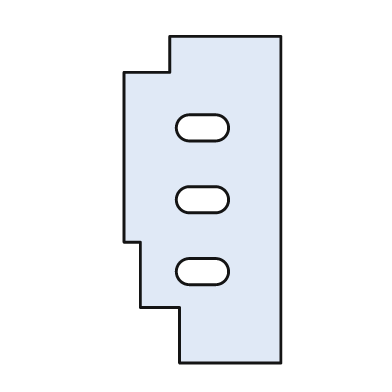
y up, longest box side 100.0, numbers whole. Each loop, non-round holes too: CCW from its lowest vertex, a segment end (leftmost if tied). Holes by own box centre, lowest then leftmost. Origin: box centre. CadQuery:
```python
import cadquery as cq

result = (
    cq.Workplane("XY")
    .moveTo(-7.0, -50.0)
    .lineTo(24.0, -50.0)
    .lineTo(24.0, 50.0)
    .lineTo(-10.0, 50.0)
    .lineTo(-10.0, 39.0)
    .lineTo(-24.0, 39.0)
    .lineTo(-24.0, -13.0)
    .lineTo(-19.0, -13.0)
    .lineTo(-19.0, -33.0)
    .lineTo(-7.0, -33.0)
    .close()
    .moveTo(-4.0, -26.0)
    .lineTo(4.0, -26.0)
    .threePointArc((8.0, -22.0), (4.0, -18.0))
    .lineTo(-4.0, -18.0)
    .threePointArc((-8.0, -22.0), (-4.0, -26.0))
    .close()
    .moveTo(-4.0, -4.0)
    .lineTo(4.0, -4.0)
    .threePointArc((8.0, 0.0), (4.0, 4.0))
    .lineTo(-4.0, 4.0)
    .threePointArc((-8.0, 0.0), (-4.0, -4.0))
    .close()
    .moveTo(-4.0, 18.0)
    .lineTo(4.0, 18.0)
    .threePointArc((8.0, 22.0), (4.0, 26.0))
    .lineTo(-4.0, 26.0)
    .threePointArc((-8.0, 22.0), (-4.0, 18.0))
    .close()
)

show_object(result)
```